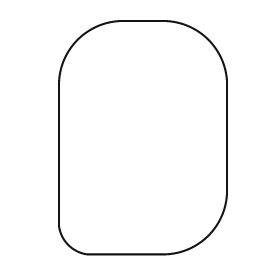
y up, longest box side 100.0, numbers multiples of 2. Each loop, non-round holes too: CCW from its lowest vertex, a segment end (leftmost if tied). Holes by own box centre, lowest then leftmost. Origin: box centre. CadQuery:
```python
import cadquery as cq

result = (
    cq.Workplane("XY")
    .moveTo(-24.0, -50.0)
    .lineTo(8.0, -50.0)
    .threePointArc((28.0, -42.0), (36.0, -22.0))
    .lineTo(36.0, 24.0)
    .threePointArc((28.0, 42.0), (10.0, 50.0))
    .lineTo(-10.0, 50.0)
    .threePointArc((-28.0, 42.0), (-36.0, 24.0))
    .lineTo(-36.0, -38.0)
    .threePointArc((-32.0, -46.0), (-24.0, -50.0))
    .close()
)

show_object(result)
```